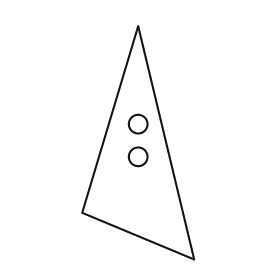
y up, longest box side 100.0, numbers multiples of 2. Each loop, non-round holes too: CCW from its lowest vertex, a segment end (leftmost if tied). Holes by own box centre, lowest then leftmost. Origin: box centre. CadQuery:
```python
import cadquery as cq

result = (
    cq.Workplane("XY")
    .moveTo(24.0, -50.0)
    .lineTo(0.0, 50.0)
    .lineTo(-24.0, -30.0)
    .close()
    .moveTo(0.0, -6.0)
    .circle(4.0)
    .moveTo(0.0, 8.0)
    .circle(4.0)
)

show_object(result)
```